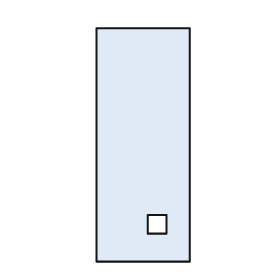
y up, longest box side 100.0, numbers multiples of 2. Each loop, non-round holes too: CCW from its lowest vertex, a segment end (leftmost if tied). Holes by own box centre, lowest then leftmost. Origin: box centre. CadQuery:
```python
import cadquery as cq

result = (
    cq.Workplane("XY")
    .moveTo(-20.0, -50.0)
    .lineTo(20.0, -50.0)
    .lineTo(20.0, 50.0)
    .lineTo(-20.0, 50.0)
    .close()
    .moveTo(2.0, -38.0)
    .lineTo(10.0, -38.0)
    .lineTo(10.0, -30.0)
    .lineTo(2.0, -30.0)
    .close()
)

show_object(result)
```